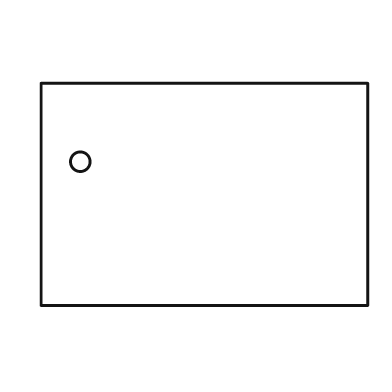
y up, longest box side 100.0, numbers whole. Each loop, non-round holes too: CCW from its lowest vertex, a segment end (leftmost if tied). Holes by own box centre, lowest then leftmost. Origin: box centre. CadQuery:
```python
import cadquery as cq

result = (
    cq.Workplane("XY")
    .moveTo(-50.0, -34.0)
    .lineTo(50.0, -34.0)
    .lineTo(50.0, 34.0)
    .lineTo(-50.0, 34.0)
    .close()
    .moveTo(-38.0, 10.0)
    .circle(3.0)
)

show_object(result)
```